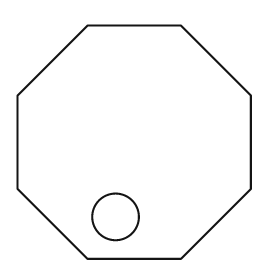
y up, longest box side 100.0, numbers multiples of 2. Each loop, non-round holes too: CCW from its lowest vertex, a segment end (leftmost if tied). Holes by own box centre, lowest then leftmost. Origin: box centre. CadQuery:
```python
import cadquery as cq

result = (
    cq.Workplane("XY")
    .moveTo(-20.0, -50.0)
    .lineTo(20.0, -50.0)
    .lineTo(50.0, -20.0)
    .lineTo(50.0, 20.0)
    .lineTo(20.0, 50.0)
    .lineTo(-20.0, 50.0)
    .lineTo(-50.0, 20.0)
    .lineTo(-50.0, -20.0)
    .close()
    .moveTo(-8.0, -32.0)
    .circle(10.0)
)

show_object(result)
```